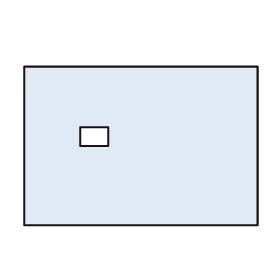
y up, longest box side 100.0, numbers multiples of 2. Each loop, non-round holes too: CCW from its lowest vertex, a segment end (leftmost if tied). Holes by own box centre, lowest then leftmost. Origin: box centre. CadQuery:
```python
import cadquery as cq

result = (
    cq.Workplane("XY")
    .moveTo(-50.0, -34.0)
    .lineTo(50.0, -34.0)
    .lineTo(50.0, 34.0)
    .lineTo(-50.0, 34.0)
    .close()
    .moveTo(-26.0, 0.0)
    .lineTo(-14.0, 0.0)
    .lineTo(-14.0, 8.0)
    .lineTo(-26.0, 8.0)
    .close()
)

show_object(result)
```